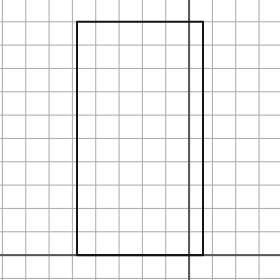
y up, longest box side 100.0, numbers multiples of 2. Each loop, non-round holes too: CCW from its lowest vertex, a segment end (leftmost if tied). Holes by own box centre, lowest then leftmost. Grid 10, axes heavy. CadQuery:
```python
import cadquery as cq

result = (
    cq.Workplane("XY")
    .moveTo(-48.0, 0.0)
    .lineTo(6.0, 0.0)
    .lineTo(6.0, 100.0)
    .lineTo(-48.0, 100.0)
    .close()
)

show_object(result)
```